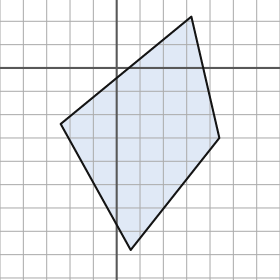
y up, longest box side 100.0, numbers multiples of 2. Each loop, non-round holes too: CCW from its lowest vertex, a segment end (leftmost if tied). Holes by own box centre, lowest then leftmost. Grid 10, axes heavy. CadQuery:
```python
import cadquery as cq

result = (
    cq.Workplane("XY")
    .moveTo(6.0, -78.0)
    .lineTo(44.0, -30.0)
    .lineTo(32.0, 22.0)
    .lineTo(-24.0, -24.0)
    .close()
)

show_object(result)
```